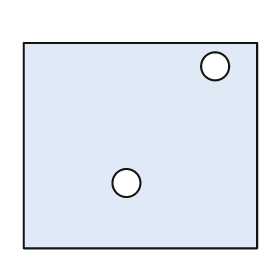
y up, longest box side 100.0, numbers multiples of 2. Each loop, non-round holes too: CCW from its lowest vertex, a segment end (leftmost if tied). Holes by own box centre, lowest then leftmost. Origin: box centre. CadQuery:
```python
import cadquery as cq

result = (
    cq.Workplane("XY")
    .moveTo(-50.0, -44.0)
    .lineTo(50.0, -44.0)
    .lineTo(50.0, 44.0)
    .lineTo(-50.0, 44.0)
    .close()
    .moveTo(-6.0, -16.0)
    .circle(6.0)
    .moveTo(32.0, 34.0)
    .circle(6.0)
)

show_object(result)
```